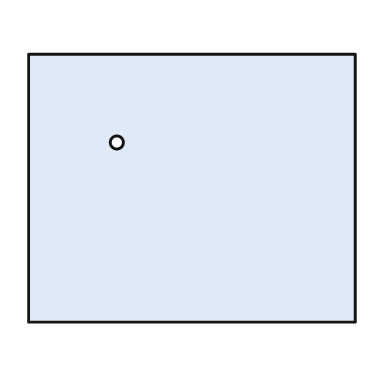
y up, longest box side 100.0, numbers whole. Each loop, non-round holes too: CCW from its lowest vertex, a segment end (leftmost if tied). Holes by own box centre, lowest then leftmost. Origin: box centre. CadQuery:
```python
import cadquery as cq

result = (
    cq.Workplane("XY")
    .moveTo(-50.0, -41.0)
    .lineTo(50.0, -41.0)
    .lineTo(50.0, 41.0)
    .lineTo(-50.0, 41.0)
    .close()
    .moveTo(-23.0, 14.0)
    .circle(2.0)
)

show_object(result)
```